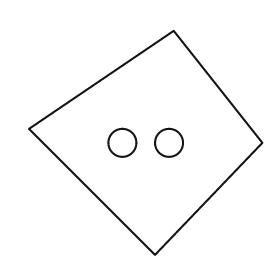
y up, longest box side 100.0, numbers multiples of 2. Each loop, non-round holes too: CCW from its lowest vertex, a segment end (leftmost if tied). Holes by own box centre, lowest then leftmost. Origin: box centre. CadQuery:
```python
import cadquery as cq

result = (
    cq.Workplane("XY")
    .moveTo(4.0, -48.0)
    .lineTo(50.0, 0.0)
    .lineTo(12.0, 48.0)
    .lineTo(-50.0, 6.0)
    .close()
    .moveTo(-10.0, 0.0)
    .circle(6.0)
    .moveTo(10.0, 0.0)
    .circle(6.0)
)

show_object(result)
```